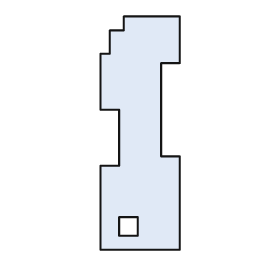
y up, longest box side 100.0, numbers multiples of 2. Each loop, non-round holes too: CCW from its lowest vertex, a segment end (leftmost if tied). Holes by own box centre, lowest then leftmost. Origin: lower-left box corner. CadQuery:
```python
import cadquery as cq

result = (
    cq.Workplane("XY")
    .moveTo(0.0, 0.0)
    .lineTo(34.0, 0.0)
    .lineTo(34.0, 40.0)
    .lineTo(26.0, 40.0)
    .lineTo(26.0, 80.0)
    .lineTo(34.0, 80.0)
    .lineTo(34.0, 100.0)
    .lineTo(10.0, 100.0)
    .lineTo(10.0, 94.0)
    .lineTo(4.0, 94.0)
    .lineTo(4.0, 84.0)
    .lineTo(0.0, 84.0)
    .lineTo(0.0, 60.0)
    .lineTo(8.0, 60.0)
    .lineTo(8.0, 36.0)
    .lineTo(0.0, 36.0)
    .close()
    .moveTo(8.0, 6.0)
    .lineTo(16.0, 6.0)
    .lineTo(16.0, 14.0)
    .lineTo(8.0, 14.0)
    .close()
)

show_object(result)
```